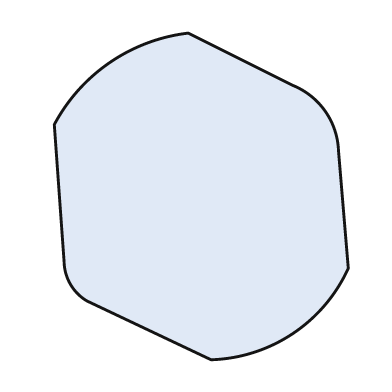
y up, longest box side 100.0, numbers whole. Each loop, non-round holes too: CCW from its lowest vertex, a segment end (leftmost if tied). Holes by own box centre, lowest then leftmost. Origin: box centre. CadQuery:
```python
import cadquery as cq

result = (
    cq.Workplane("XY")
    .moveTo(3.0, -50.0)
    .threePointArc((28.0, -42.0), (45.0, -22.0))
    .lineTo(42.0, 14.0)
    .threePointArc((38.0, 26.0), (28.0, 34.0))
    .lineTo(-4.0, 50.0)
    .threePointArc((-28.0, 41.0), (-45.0, 22.0))
    .lineTo(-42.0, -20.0)
    .threePointArc((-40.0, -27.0), (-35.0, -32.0))
    .close()
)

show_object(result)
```